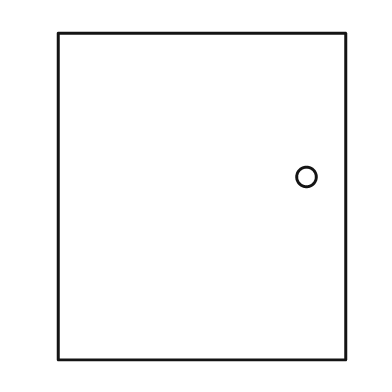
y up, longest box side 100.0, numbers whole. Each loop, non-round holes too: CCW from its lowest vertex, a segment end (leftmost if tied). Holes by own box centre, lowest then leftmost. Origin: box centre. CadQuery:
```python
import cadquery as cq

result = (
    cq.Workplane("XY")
    .moveTo(-44.0, -50.0)
    .lineTo(44.0, -50.0)
    .lineTo(44.0, 50.0)
    .lineTo(-44.0, 50.0)
    .close()
    .moveTo(32.0, 6.0)
    .circle(3.0)
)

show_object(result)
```